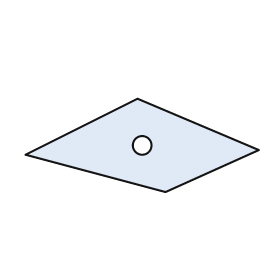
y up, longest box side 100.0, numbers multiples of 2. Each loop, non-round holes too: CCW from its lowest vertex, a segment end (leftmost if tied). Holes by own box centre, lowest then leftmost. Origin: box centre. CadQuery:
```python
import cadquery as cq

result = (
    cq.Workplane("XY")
    .moveTo(10.0, -20.0)
    .lineTo(50.0, -2.0)
    .lineTo(-2.0, 20.0)
    .lineTo(-50.0, -4.0)
    .close()
    .moveTo(0.0, 0.0)
    .circle(4.0)
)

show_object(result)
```